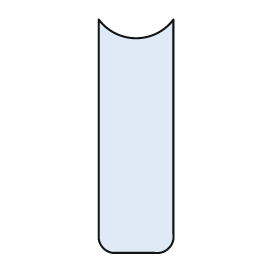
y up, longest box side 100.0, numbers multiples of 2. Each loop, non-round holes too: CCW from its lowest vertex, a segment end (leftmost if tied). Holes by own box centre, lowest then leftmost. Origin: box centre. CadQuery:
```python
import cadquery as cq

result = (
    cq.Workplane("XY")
    .moveTo(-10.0, -50.0)
    .lineTo(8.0, -50.0)
    .threePointArc((14.0, -48.0), (16.0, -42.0))
    .lineTo(16.0, 50.0)
    .threePointArc((0.0, 42.0), (-16.0, 50.0))
    .lineTo(-16.0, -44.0)
    .threePointArc((-14.0, -48.0), (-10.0, -50.0))
    .close()
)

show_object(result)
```